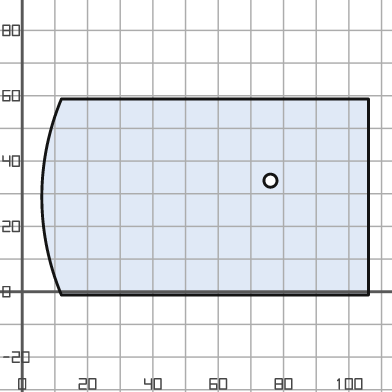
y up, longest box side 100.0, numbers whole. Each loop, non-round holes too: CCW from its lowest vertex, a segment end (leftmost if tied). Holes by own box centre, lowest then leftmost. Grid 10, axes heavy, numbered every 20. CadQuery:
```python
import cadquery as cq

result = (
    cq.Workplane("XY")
    .moveTo(12.0, -1.0)
    .lineTo(106.0, -1.0)
    .lineTo(106.0, 59.0)
    .lineTo(12.0, 59.0)
    .threePointArc((6.0, 29.0), (12.0, -1.0))
    .close()
    .moveTo(76.0, 34.0)
    .circle(2.0)
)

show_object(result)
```